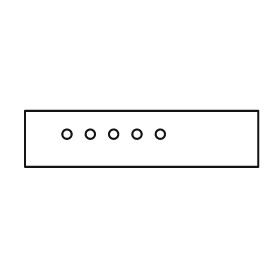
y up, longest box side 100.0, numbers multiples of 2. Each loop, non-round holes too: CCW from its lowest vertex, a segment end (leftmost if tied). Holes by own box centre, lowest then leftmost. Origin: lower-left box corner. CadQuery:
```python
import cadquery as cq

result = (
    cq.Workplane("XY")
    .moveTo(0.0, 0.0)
    .lineTo(100.0, 0.0)
    .lineTo(100.0, 24.0)
    .lineTo(0.0, 24.0)
    .close()
    .moveTo(18.0, 14.0)
    .circle(2.0)
    .moveTo(28.0, 14.0)
    .circle(2.0)
    .moveTo(38.0, 14.0)
    .circle(2.0)
    .moveTo(48.0, 14.0)
    .circle(2.0)
    .moveTo(58.0, 14.0)
    .circle(2.0)
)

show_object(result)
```